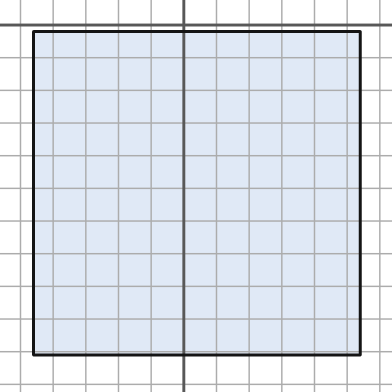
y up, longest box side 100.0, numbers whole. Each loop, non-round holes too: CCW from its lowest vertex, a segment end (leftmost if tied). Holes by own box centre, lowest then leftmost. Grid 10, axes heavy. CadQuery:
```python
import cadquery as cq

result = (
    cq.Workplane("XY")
    .moveTo(-46.0, -101.0)
    .lineTo(54.0, -101.0)
    .lineTo(54.0, -2.0)
    .lineTo(-46.0, -2.0)
    .close()
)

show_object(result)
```